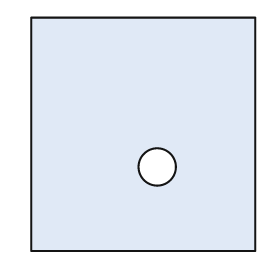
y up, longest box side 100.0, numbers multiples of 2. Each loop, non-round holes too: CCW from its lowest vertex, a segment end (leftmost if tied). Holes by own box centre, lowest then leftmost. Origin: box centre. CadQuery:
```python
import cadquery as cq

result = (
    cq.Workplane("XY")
    .moveTo(-48.0, -50.0)
    .lineTo(48.0, -50.0)
    .lineTo(48.0, 50.0)
    .lineTo(-48.0, 50.0)
    .close()
    .moveTo(6.0, -14.0)
    .circle(8.0)
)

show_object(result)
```